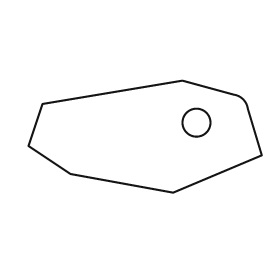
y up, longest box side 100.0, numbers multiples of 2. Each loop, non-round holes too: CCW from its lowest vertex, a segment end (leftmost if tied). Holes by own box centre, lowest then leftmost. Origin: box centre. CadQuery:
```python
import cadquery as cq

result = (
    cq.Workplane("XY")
    .moveTo(12.0, -24.0)
    .lineTo(50.0, -8.0)
    .lineTo(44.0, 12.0)
    .threePointArc((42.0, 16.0), (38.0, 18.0))
    .lineTo(16.0, 24.0)
    .lineTo(-44.0, 14.0)
    .lineTo(-50.0, -4.0)
    .lineTo(-32.0, -16.0)
    .close()
    .moveTo(22.0, 6.0)
    .circle(6.0)
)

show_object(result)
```